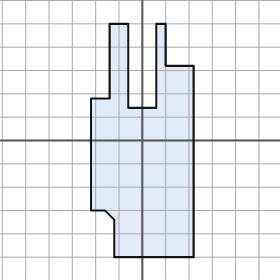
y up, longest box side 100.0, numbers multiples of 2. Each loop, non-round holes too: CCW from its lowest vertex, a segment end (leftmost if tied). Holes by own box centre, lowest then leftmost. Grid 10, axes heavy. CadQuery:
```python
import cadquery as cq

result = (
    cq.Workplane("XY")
    .moveTo(-12.0, -50.0)
    .lineTo(22.0, -50.0)
    .lineTo(22.0, 32.0)
    .lineTo(10.0, 32.0)
    .lineTo(10.0, 50.0)
    .lineTo(6.0, 50.0)
    .lineTo(6.0, 14.0)
    .lineTo(-6.0, 14.0)
    .lineTo(-6.0, 50.0)
    .lineTo(-14.0, 50.0)
    .lineTo(-14.0, 18.0)
    .lineTo(-22.0, 18.0)
    .lineTo(-22.0, -30.0)
    .lineTo(-16.0, -30.0)
    .lineTo(-12.0, -34.0)
    .close()
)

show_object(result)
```